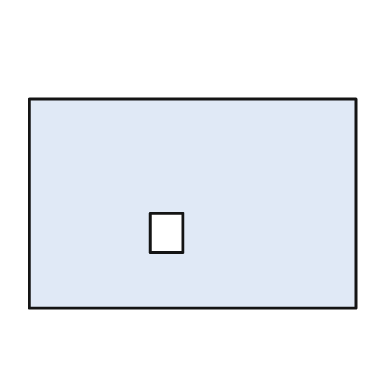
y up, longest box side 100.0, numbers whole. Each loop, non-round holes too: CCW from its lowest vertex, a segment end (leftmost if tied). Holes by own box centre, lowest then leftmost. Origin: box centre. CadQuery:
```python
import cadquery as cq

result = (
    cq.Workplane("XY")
    .moveTo(-50.0, -32.0)
    .lineTo(50.0, -32.0)
    .lineTo(50.0, 32.0)
    .lineTo(-50.0, 32.0)
    .close()
    .moveTo(-13.0, -15.0)
    .lineTo(-3.0, -15.0)
    .lineTo(-3.0, -3.0)
    .lineTo(-13.0, -3.0)
    .close()
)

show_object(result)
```